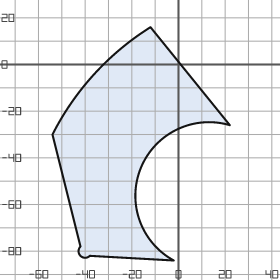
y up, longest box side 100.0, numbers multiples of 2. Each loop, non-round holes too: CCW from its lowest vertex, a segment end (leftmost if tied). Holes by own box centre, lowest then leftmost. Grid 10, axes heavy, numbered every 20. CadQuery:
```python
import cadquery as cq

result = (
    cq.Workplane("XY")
    .moveTo(-2.0, -84.0)
    .threePointArc((-16.0, -44.0), (22.0, -26.0))
    .lineTo(-12.0, 16.0)
    .threePointArc((-36.0, -4.0), (-54.0, -30.0))
    .lineTo(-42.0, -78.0)
    .threePointArc((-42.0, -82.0), (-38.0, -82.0))
    .close()
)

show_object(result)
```